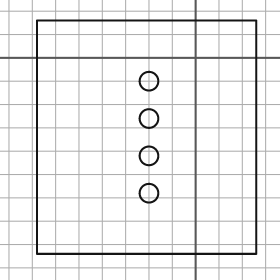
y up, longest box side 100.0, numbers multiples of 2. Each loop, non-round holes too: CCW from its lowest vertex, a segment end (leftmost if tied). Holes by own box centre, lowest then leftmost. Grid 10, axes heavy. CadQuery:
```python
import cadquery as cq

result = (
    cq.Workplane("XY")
    .moveTo(-68.0, -84.0)
    .lineTo(26.0, -84.0)
    .lineTo(26.0, 16.0)
    .lineTo(-68.0, 16.0)
    .close()
    .moveTo(-20.0, -58.0)
    .circle(4.0)
    .moveTo(-20.0, -42.0)
    .circle(4.0)
    .moveTo(-20.0, -26.0)
    .circle(4.0)
    .moveTo(-20.0, -10.0)
    .circle(4.0)
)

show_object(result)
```